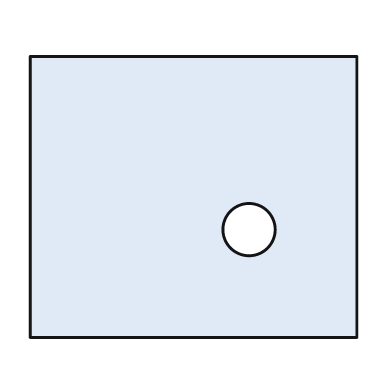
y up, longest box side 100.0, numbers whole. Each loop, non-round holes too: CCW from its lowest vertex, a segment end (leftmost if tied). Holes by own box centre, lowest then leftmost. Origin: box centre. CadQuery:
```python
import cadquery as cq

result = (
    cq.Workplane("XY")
    .moveTo(-50.0, -43.0)
    .lineTo(50.0, -43.0)
    .lineTo(50.0, 43.0)
    .lineTo(-50.0, 43.0)
    .close()
    .moveTo(17.0, -10.0)
    .circle(8.0)
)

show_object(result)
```